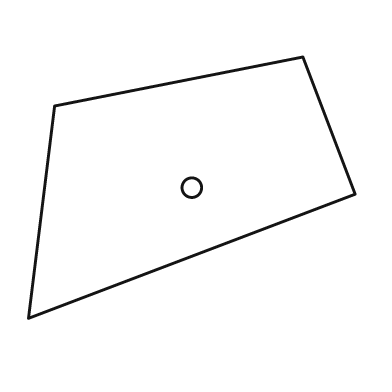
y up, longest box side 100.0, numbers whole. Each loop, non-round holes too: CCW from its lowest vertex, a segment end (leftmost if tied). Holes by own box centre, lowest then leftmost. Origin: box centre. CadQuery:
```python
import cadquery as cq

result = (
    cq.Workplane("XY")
    .moveTo(-50.0, -40.0)
    .lineTo(50.0, -2.0)
    .lineTo(34.0, 40.0)
    .lineTo(-42.0, 25.0)
    .close()
    .moveTo(0.0, 0.0)
    .circle(3.0)
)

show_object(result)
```